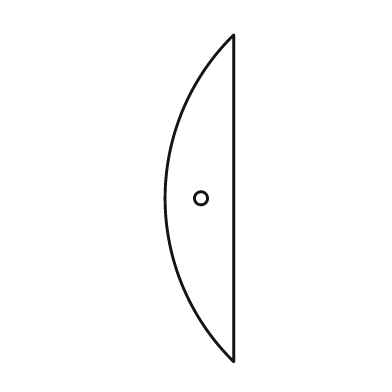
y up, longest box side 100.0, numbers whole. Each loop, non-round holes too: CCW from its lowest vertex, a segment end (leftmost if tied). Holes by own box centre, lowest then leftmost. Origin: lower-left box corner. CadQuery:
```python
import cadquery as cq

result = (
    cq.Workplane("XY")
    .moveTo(21.0, 0.0)
    .lineTo(21.0, 100.0)
    .threePointArc((0.0, 50.0), (21.0, 0.0))
    .close()
    .moveTo(11.0, 50.0)
    .circle(2.0)
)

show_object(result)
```